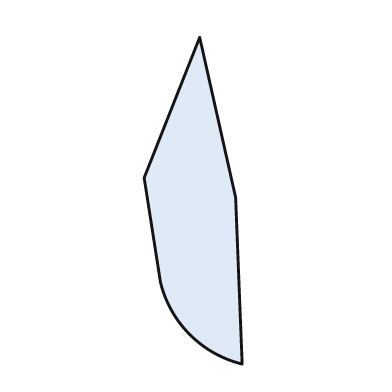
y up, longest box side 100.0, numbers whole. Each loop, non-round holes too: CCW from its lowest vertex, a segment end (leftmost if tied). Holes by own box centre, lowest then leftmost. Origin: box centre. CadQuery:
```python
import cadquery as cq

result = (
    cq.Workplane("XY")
    .moveTo(15.0, -50.0)
    .lineTo(13.0, 1.0)
    .lineTo(2.0, 50.0)
    .lineTo(-15.0, 7.0)
    .lineTo(-10.0, -25.0)
    .threePointArc((-1.0, -41.0), (15.0, -50.0))
    .close()
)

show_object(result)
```